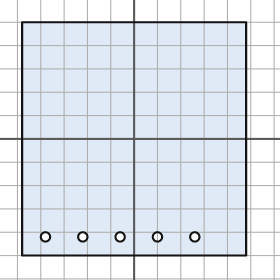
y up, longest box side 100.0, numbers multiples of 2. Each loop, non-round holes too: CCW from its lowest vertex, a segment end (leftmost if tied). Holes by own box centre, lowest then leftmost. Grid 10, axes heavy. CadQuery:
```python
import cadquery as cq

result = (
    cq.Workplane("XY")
    .moveTo(-48.0, -50.0)
    .lineTo(48.0, -50.0)
    .lineTo(48.0, 50.0)
    .lineTo(-48.0, 50.0)
    .close()
    .moveTo(-38.0, -42.0)
    .circle(2.0)
    .moveTo(-22.0, -42.0)
    .circle(2.0)
    .moveTo(-6.0, -42.0)
    .circle(2.0)
    .moveTo(10.0, -42.0)
    .circle(2.0)
    .moveTo(26.0, -42.0)
    .circle(2.0)
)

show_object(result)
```